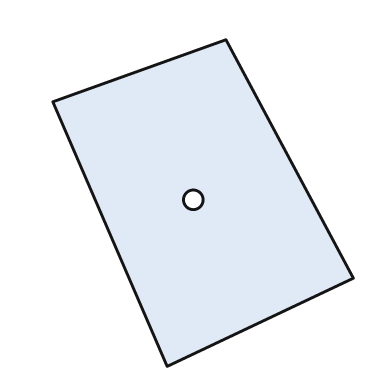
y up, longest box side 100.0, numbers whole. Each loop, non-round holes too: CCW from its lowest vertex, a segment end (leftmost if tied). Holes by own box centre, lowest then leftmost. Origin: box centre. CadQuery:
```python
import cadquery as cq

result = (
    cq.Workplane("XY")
    .moveTo(-11.0, -50.0)
    .lineTo(46.0, -23.0)
    .lineTo(7.0, 50.0)
    .lineTo(-46.0, 31.0)
    .close()
    .moveTo(-3.0, 1.0)
    .circle(3.0)
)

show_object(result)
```